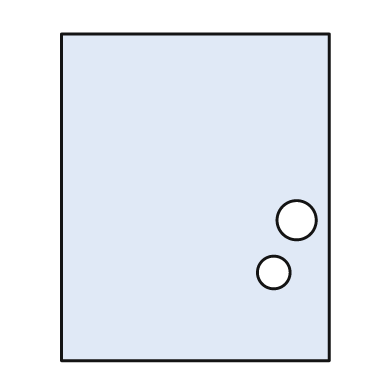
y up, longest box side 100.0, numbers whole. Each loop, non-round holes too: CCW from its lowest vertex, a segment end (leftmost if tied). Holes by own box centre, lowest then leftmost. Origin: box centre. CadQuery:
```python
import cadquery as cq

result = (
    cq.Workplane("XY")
    .moveTo(-41.0, -50.0)
    .lineTo(41.0, -50.0)
    .lineTo(41.0, 50.0)
    .lineTo(-41.0, 50.0)
    .close()
    .moveTo(24.0, -23.0)
    .circle(5.0)
    .moveTo(31.0, -7.0)
    .circle(6.0)
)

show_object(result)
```